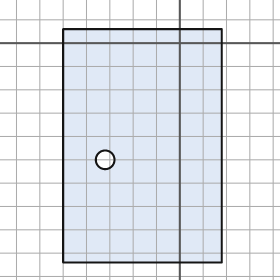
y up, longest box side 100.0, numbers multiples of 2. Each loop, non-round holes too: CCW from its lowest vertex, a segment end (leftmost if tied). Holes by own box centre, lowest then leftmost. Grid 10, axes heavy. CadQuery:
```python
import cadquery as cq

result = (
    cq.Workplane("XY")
    .moveTo(-50.0, -94.0)
    .lineTo(18.0, -94.0)
    .lineTo(18.0, 6.0)
    .lineTo(-50.0, 6.0)
    .close()
    .moveTo(-32.0, -50.0)
    .circle(4.0)
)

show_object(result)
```